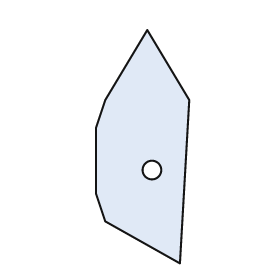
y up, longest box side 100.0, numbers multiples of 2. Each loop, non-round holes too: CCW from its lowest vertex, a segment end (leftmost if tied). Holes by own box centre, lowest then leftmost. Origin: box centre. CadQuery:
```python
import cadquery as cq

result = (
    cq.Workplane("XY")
    .moveTo(16.0, -50.0)
    .lineTo(20.0, 20.0)
    .lineTo(2.0, 50.0)
    .lineTo(-16.0, 20.0)
    .lineTo(-20.0, 8.0)
    .lineTo(-20.0, -20.0)
    .lineTo(-16.0, -32.0)
    .close()
    .moveTo(4.0, -10.0)
    .circle(4.0)
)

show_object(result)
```